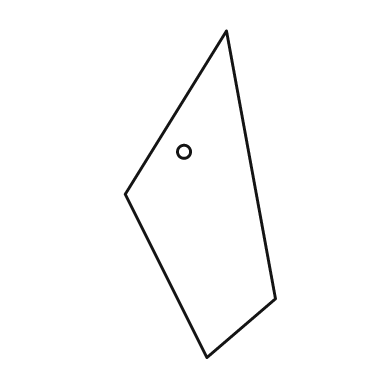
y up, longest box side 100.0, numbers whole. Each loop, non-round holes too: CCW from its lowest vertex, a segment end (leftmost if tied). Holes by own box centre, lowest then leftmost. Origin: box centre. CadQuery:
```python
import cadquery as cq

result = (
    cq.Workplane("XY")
    .moveTo(2.0, -50.0)
    .lineTo(23.0, -32.0)
    .lineTo(8.0, 50.0)
    .lineTo(-23.0, 0.0)
    .close()
    .moveTo(-5.0, 13.0)
    .circle(2.0)
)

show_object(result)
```